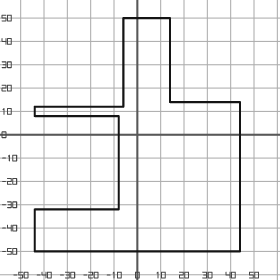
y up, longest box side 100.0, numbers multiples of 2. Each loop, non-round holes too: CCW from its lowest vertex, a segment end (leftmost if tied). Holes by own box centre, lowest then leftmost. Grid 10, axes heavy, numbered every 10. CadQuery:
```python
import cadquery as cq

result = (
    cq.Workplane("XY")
    .moveTo(-44.0, -50.0)
    .lineTo(44.0, -50.0)
    .lineTo(44.0, 14.0)
    .lineTo(14.0, 14.0)
    .lineTo(14.0, 50.0)
    .lineTo(-6.0, 50.0)
    .lineTo(-6.0, 12.0)
    .lineTo(-44.0, 12.0)
    .lineTo(-44.0, 8.0)
    .lineTo(-8.0, 8.0)
    .lineTo(-8.0, -32.0)
    .lineTo(-44.0, -32.0)
    .close()
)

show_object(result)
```